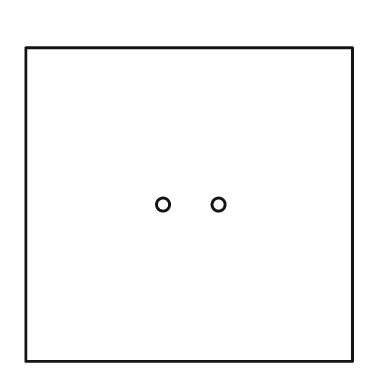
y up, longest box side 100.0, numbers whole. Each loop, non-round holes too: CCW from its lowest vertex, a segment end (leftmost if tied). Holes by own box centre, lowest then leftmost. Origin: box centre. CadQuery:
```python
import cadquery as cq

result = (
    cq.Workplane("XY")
    .moveTo(-50.0, -48.0)
    .lineTo(50.0, -48.0)
    .lineTo(50.0, 48.0)
    .lineTo(-50.0, 48.0)
    .close()
    .moveTo(-8.0, 0.0)
    .circle(2.0)
    .moveTo(9.0, 0.0)
    .circle(2.0)
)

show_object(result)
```